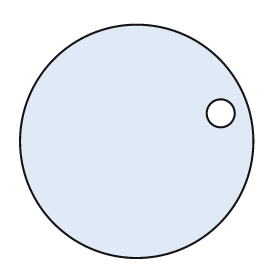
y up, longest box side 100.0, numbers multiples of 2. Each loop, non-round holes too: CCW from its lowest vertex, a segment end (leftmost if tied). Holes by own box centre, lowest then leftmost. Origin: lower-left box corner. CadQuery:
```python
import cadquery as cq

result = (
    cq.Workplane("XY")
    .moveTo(50.0, 50.0)
    .circle(50.0)
    .moveTo(86.0, 62.0)
    .circle(6.0)
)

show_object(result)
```